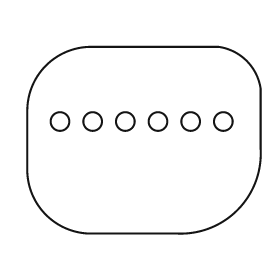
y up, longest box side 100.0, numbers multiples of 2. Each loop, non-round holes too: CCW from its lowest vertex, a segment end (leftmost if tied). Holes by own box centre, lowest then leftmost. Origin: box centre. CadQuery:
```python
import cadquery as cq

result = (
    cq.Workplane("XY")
    .moveTo(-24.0, -40.0)
    .lineTo(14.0, -40.0)
    .threePointArc((40.0, -30.0), (50.0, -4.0))
    .lineTo(50.0, 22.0)
    .threePointArc((44.0, 34.0), (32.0, 40.0))
    .lineTo(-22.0, 40.0)
    .threePointArc((-42.0, 32.0), (-50.0, 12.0))
    .lineTo(-50.0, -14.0)
    .threePointArc((-42.0, -32.0), (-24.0, -40.0))
    .close()
    .moveTo(-36.0, 8.0)
    .circle(4.0)
    .moveTo(-22.0, 8.0)
    .circle(4.0)
    .moveTo(-8.0, 8.0)
    .circle(4.0)
    .moveTo(6.0, 8.0)
    .circle(4.0)
    .moveTo(20.0, 8.0)
    .circle(4.0)
    .moveTo(34.0, 8.0)
    .circle(4.0)
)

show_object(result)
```